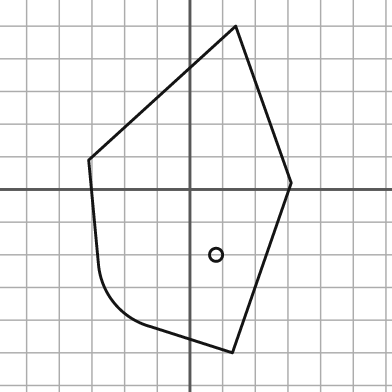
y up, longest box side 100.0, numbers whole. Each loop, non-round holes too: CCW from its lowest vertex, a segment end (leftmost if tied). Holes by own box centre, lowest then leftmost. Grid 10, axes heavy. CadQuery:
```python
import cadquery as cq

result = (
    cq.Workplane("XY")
    .moveTo(13.0, -50.0)
    .lineTo(31.0, 2.0)
    .lineTo(14.0, 50.0)
    .lineTo(-31.0, 9.0)
    .lineTo(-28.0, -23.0)
    .threePointArc((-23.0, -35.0), (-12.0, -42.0))
    .close()
    .moveTo(8.0, -20.0)
    .circle(2.0)
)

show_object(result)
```